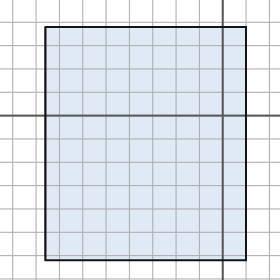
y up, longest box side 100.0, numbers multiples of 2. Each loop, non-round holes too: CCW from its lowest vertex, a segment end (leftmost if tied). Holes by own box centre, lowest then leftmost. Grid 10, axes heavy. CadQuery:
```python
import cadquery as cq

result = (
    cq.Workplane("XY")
    .moveTo(-76.0, -62.0)
    .lineTo(10.0, -62.0)
    .lineTo(10.0, 38.0)
    .lineTo(-76.0, 38.0)
    .close()
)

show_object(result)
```